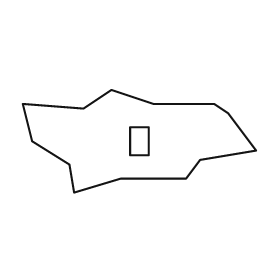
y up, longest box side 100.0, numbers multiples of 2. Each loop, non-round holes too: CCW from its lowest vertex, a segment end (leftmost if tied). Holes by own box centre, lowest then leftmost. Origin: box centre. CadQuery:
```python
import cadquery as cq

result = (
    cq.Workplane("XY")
    .moveTo(-28.0, -22.0)
    .lineTo(-8.0, -16.0)
    .lineTo(20.0, -16.0)
    .lineTo(26.0, -8.0)
    .lineTo(50.0, -4.0)
    .lineTo(38.0, 12.0)
    .lineTo(32.0, 16.0)
    .lineTo(6.0, 16.0)
    .lineTo(-12.0, 22.0)
    .lineTo(-24.0, 14.0)
    .lineTo(-50.0, 16.0)
    .lineTo(-46.0, 0.0)
    .lineTo(-30.0, -10.0)
    .close()
    .moveTo(-4.0, -6.0)
    .lineTo(4.0, -6.0)
    .lineTo(4.0, 6.0)
    .lineTo(-4.0, 6.0)
    .close()
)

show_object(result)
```